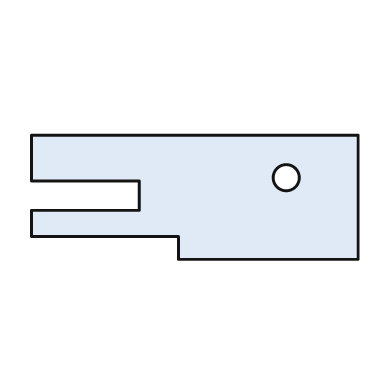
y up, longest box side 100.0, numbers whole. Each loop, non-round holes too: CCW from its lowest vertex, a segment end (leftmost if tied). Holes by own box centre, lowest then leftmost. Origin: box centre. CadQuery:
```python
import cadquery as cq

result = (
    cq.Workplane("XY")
    .moveTo(-5.0, -19.0)
    .lineTo(50.0, -19.0)
    .lineTo(50.0, 19.0)
    .lineTo(-50.0, 19.0)
    .lineTo(-50.0, 5.0)
    .lineTo(-17.0, 5.0)
    .lineTo(-17.0, -4.0)
    .lineTo(-50.0, -4.0)
    .lineTo(-50.0, -12.0)
    .lineTo(-5.0, -12.0)
    .close()
    .moveTo(28.0, 6.0)
    .circle(4.0)
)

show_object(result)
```